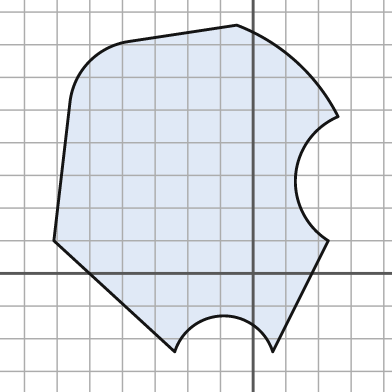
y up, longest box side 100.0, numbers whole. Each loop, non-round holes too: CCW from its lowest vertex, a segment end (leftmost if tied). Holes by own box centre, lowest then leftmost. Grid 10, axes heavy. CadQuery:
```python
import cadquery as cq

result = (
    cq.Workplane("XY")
    .moveTo(-24.0, -24.0)
    .threePointArc((-9.0, -13.0), (6.0, -24.0))
    .lineTo(23.0, 10.0)
    .threePointArc((13.0, 30.0), (26.0, 48.0))
    .threePointArc((13.0, 65.0), (-5.0, 76.0))
    .lineTo(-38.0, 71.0)
    .threePointArc((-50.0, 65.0), (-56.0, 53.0))
    .lineTo(-61.0, 10.0)
    .close()
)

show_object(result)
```